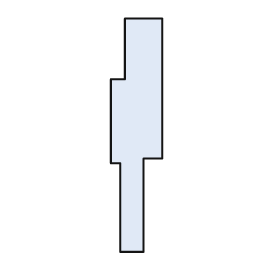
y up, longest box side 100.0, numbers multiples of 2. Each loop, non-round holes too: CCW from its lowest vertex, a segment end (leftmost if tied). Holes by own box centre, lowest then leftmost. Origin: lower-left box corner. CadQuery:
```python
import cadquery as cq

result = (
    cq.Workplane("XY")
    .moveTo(4.0, 0.0)
    .lineTo(14.0, 0.0)
    .lineTo(14.0, 40.0)
    .lineTo(22.0, 40.0)
    .lineTo(22.0, 100.0)
    .lineTo(6.0, 100.0)
    .lineTo(6.0, 74.0)
    .lineTo(0.0, 74.0)
    .lineTo(0.0, 38.0)
    .lineTo(4.0, 38.0)
    .close()
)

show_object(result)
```